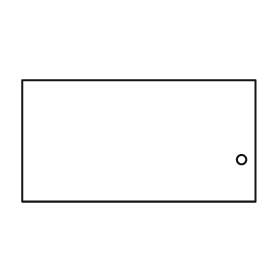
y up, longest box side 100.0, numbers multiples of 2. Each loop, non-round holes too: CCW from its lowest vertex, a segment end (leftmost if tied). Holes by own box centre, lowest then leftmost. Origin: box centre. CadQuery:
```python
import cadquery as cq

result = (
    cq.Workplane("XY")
    .moveTo(-50.0, -26.0)
    .lineTo(50.0, -26.0)
    .lineTo(50.0, 26.0)
    .lineTo(-50.0, 26.0)
    .close()
    .moveTo(44.0, -8.0)
    .circle(2.0)
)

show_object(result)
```